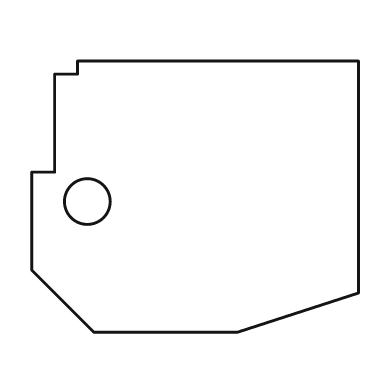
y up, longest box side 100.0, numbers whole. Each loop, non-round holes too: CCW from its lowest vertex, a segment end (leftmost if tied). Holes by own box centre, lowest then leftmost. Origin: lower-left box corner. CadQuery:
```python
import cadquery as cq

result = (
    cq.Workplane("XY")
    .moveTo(19.0, 0.0)
    .lineTo(63.0, 0.0)
    .lineTo(100.0, 12.0)
    .lineTo(100.0, 83.0)
    .lineTo(14.0, 83.0)
    .lineTo(14.0, 79.0)
    .lineTo(7.0, 79.0)
    .lineTo(7.0, 49.0)
    .lineTo(0.0, 49.0)
    .lineTo(0.0, 19.0)
    .close()
    .moveTo(17.0, 40.0)
    .circle(7.0)
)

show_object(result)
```